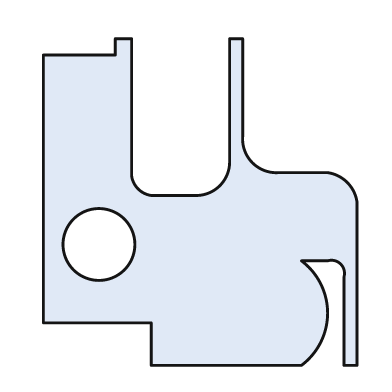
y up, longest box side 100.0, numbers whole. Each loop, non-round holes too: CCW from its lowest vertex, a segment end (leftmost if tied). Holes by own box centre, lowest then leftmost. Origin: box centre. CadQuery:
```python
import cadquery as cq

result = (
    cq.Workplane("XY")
    .moveTo(-15.0, -50.0)
    .lineTo(31.0, -50.0)
    .threePointArc((39.0, -34.0), (31.0, -18.0))
    .lineTo(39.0, -18.0)
    .threePointArc((43.0, -19.0), (44.0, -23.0))
    .lineTo(44.0, -50.0)
    .lineTo(48.0, -50.0)
    .lineTo(48.0, 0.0)
    .threePointArc((45.0, 6.0), (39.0, 9.0))
    .lineTo(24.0, 9.0)
    .threePointArc((16.0, 12.0), (13.0, 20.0))
    .lineTo(13.0, 50.0)
    .lineTo(9.0, 50.0)
    .lineTo(9.0, 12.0)
    .threePointArc((6.0, 5.0), (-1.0, 2.0))
    .lineTo(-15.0, 2.0)
    .threePointArc((-19.0, 4.0), (-21.0, 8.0))
    .lineTo(-21.0, 50.0)
    .lineTo(-26.0, 50.0)
    .lineTo(-26.0, 45.0)
    .lineTo(-48.0, 45.0)
    .lineTo(-48.0, -37.0)
    .lineTo(-15.0, -37.0)
    .close()
    .moveTo(-31.0, -13.0)
    .circle(11.0)
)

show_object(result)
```